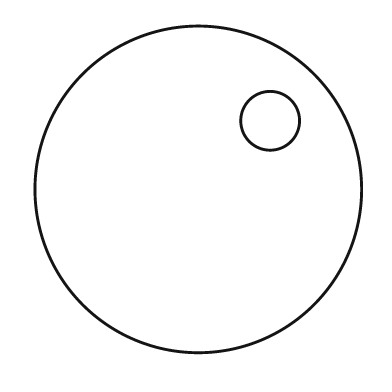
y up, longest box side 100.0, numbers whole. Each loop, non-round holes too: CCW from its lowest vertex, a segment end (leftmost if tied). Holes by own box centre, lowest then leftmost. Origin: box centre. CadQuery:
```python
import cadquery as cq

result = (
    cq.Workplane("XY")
    .moveTo(0.0, 0.0)
    .circle(50.0)
    .moveTo(22.0, 21.0)
    .circle(9.0)
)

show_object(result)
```